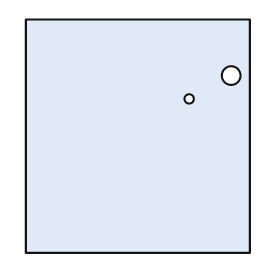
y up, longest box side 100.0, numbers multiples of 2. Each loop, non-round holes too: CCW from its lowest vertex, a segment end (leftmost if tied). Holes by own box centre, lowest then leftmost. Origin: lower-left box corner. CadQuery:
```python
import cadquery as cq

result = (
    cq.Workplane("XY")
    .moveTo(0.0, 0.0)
    .lineTo(96.0, 0.0)
    .lineTo(96.0, 100.0)
    .lineTo(0.0, 100.0)
    .close()
    .moveTo(70.0, 66.0)
    .circle(2.0)
    .moveTo(88.0, 76.0)
    .circle(4.0)
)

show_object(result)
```